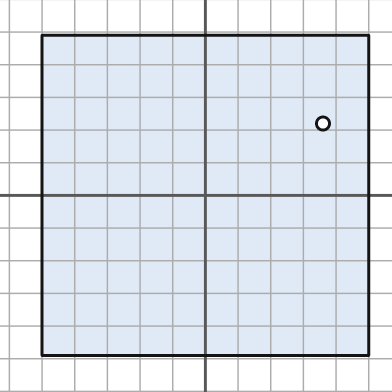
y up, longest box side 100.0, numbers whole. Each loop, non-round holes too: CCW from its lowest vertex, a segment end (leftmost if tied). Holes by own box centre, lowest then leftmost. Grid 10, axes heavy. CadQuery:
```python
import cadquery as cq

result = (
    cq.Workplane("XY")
    .moveTo(-50.0, -49.0)
    .lineTo(50.0, -49.0)
    .lineTo(50.0, 49.0)
    .lineTo(-50.0, 49.0)
    .close()
    .moveTo(36.0, 22.0)
    .circle(2.0)
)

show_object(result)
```